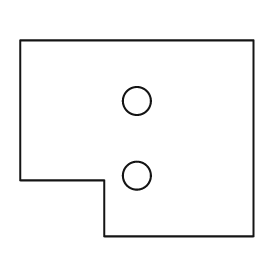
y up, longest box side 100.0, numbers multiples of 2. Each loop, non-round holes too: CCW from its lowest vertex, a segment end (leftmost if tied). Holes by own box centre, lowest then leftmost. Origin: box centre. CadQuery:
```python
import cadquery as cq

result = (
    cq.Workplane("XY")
    .moveTo(-14.0, -42.0)
    .lineTo(50.0, -42.0)
    .lineTo(50.0, 42.0)
    .lineTo(-50.0, 42.0)
    .lineTo(-50.0, -18.0)
    .lineTo(-14.0, -18.0)
    .close()
    .moveTo(0.0, -16.0)
    .circle(6.0)
    .moveTo(0.0, 16.0)
    .circle(6.0)
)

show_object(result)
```